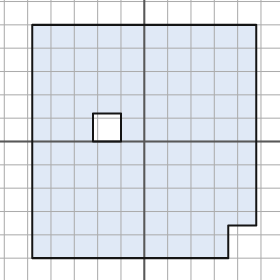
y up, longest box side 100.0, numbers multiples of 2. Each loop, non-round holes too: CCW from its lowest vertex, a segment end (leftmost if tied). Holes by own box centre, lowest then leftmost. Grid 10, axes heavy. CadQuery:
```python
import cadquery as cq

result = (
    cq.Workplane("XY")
    .moveTo(-48.0, -50.0)
    .lineTo(36.0, -50.0)
    .lineTo(36.0, -36.0)
    .lineTo(48.0, -36.0)
    .lineTo(48.0, 50.0)
    .lineTo(-48.0, 50.0)
    .close()
    .moveTo(-22.0, 0.0)
    .lineTo(-10.0, 0.0)
    .lineTo(-10.0, 12.0)
    .lineTo(-22.0, 12.0)
    .close()
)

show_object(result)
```